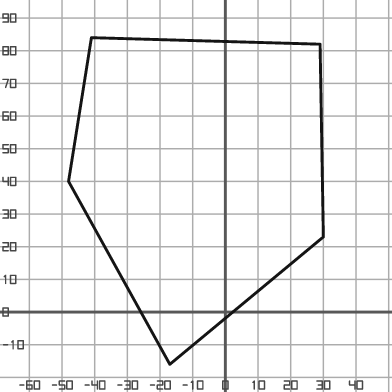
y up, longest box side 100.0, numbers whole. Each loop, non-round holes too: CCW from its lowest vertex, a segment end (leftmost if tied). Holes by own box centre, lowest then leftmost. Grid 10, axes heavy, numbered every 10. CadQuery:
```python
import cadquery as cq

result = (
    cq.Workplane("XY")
    .moveTo(-17.0, -16.0)
    .lineTo(30.0, 23.0)
    .lineTo(29.0, 82.0)
    .lineTo(-41.0, 84.0)
    .lineTo(-48.0, 40.0)
    .close()
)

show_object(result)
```